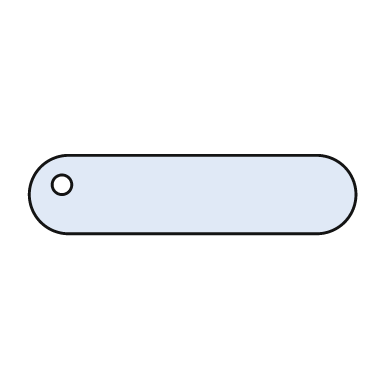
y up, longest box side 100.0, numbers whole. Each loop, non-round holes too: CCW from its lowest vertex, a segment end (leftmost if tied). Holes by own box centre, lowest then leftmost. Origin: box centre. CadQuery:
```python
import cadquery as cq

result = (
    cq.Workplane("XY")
    .moveTo(-38.0, -12.0)
    .lineTo(38.0, -12.0)
    .threePointArc((50.0, 0.0), (38.0, 12.0))
    .lineTo(-38.0, 12.0)
    .threePointArc((-50.0, 0.0), (-38.0, -12.0))
    .close()
    .moveTo(-40.0, 3.0)
    .circle(3.0)
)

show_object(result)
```